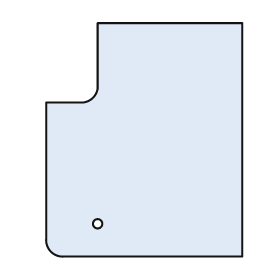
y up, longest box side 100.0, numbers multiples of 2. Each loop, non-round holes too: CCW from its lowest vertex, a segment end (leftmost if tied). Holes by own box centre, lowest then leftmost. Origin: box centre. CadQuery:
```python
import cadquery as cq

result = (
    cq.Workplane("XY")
    .moveTo(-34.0, -50.0)
    .lineTo(42.0, -50.0)
    .lineTo(42.0, 50.0)
    .lineTo(-20.0, 50.0)
    .lineTo(-20.0, 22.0)
    .threePointArc((-22.0, 18.0), (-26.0, 16.0))
    .lineTo(-42.0, 16.0)
    .lineTo(-42.0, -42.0)
    .threePointArc((-40.0, -48.0), (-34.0, -50.0))
    .close()
    .moveTo(-20.0, -36.0)
    .circle(2.0)
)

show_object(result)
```